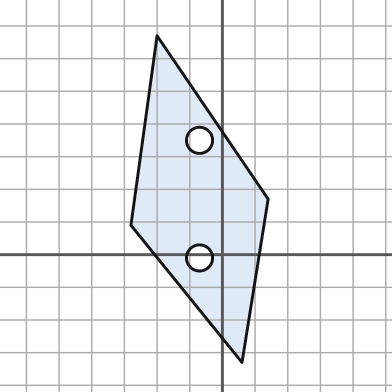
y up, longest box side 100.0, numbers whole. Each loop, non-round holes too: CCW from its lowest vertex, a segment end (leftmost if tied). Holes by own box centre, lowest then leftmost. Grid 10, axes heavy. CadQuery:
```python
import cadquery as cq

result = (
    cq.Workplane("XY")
    .moveTo(6.0, -33.0)
    .lineTo(14.0, 17.0)
    .lineTo(-20.0, 67.0)
    .lineTo(-28.0, 9.0)
    .close()
    .moveTo(-7.0, -1.0)
    .circle(4.0)
    .moveTo(-7.0, 35.0)
    .circle(4.0)
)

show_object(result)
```